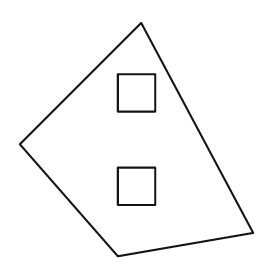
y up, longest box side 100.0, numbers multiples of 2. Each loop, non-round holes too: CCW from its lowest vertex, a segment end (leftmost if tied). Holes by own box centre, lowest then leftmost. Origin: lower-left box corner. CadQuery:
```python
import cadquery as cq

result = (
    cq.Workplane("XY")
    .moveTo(42.0, 0.0)
    .lineTo(100.0, 10.0)
    .lineTo(52.0, 100.0)
    .lineTo(0.0, 48.0)
    .close()
    .moveTo(42.0, 22.0)
    .lineTo(58.0, 22.0)
    .lineTo(58.0, 38.0)
    .lineTo(42.0, 38.0)
    .close()
    .moveTo(42.0, 62.0)
    .lineTo(58.0, 62.0)
    .lineTo(58.0, 78.0)
    .lineTo(42.0, 78.0)
    .close()
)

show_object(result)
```